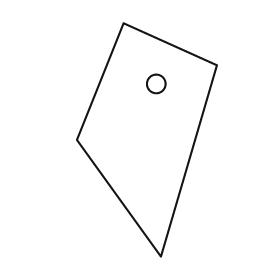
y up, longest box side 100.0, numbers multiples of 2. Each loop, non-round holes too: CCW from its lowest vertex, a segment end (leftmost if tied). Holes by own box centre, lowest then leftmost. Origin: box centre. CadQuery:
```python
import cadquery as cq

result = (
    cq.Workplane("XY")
    .moveTo(6.0, -50.0)
    .lineTo(30.0, 32.0)
    .lineTo(-10.0, 50.0)
    .lineTo(-30.0, 0.0)
    .close()
    .moveTo(4.0, 24.0)
    .circle(4.0)
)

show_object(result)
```